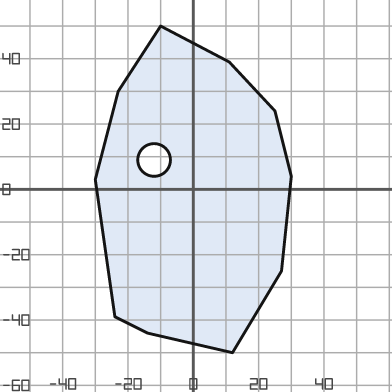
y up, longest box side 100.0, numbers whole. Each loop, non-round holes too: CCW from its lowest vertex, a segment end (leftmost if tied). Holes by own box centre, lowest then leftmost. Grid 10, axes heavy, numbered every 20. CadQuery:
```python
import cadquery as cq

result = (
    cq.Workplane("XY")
    .moveTo(12.0, -50.0)
    .lineTo(27.0, -25.0)
    .lineTo(30.0, 4.0)
    .lineTo(25.0, 24.0)
    .lineTo(11.0, 39.0)
    .lineTo(-10.0, 50.0)
    .lineTo(-23.0, 30.0)
    .lineTo(-30.0, 3.0)
    .lineTo(-24.0, -39.0)
    .lineTo(-14.0, -44.0)
    .close()
    .moveTo(-12.0, 9.0)
    .circle(5.0)
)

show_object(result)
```